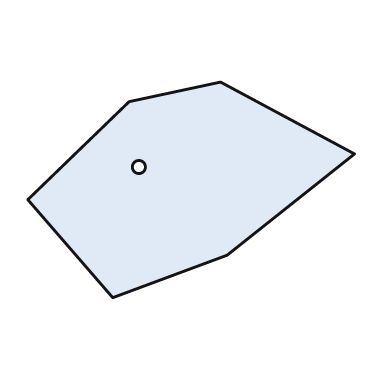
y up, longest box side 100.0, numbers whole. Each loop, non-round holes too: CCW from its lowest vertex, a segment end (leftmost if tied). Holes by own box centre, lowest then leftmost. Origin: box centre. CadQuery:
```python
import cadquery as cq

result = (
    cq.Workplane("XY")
    .moveTo(-24.0, -33.0)
    .lineTo(11.0, -20.0)
    .lineTo(50.0, 11.0)
    .lineTo(9.0, 33.0)
    .lineTo(-19.0, 27.0)
    .lineTo(-50.0, -3.0)
    .close()
    .moveTo(-16.0, 7.0)
    .circle(2.0)
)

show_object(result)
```